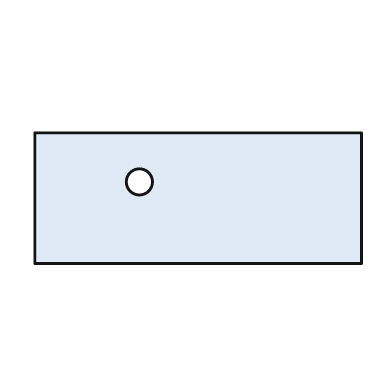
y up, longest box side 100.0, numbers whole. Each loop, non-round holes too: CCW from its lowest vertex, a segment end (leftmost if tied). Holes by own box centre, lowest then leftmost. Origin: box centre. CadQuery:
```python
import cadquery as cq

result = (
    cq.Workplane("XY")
    .moveTo(-50.0, -20.0)
    .lineTo(50.0, -20.0)
    .lineTo(50.0, 20.0)
    .lineTo(-50.0, 20.0)
    .close()
    .moveTo(-18.0, 5.0)
    .circle(4.0)
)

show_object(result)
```